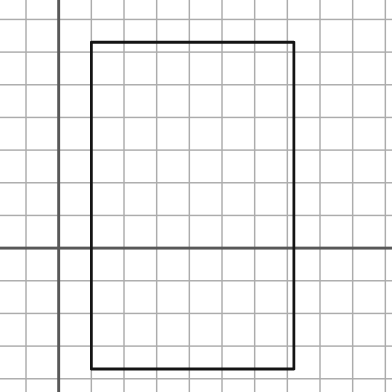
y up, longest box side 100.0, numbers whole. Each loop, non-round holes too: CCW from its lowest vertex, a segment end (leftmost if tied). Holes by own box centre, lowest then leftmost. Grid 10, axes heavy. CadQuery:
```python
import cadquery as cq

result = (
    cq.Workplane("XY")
    .moveTo(10.0, -37.0)
    .lineTo(72.0, -37.0)
    .lineTo(72.0, 63.0)
    .lineTo(10.0, 63.0)
    .close()
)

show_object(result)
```